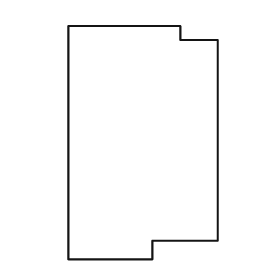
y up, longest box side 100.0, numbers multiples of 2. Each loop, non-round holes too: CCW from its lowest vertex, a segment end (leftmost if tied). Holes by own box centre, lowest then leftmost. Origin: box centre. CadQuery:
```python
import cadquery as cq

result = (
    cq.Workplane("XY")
    .moveTo(-32.0, -50.0)
    .lineTo(4.0, -50.0)
    .lineTo(4.0, -42.0)
    .lineTo(32.0, -42.0)
    .lineTo(32.0, 44.0)
    .lineTo(16.0, 44.0)
    .lineTo(16.0, 50.0)
    .lineTo(-32.0, 50.0)
    .close()
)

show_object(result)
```